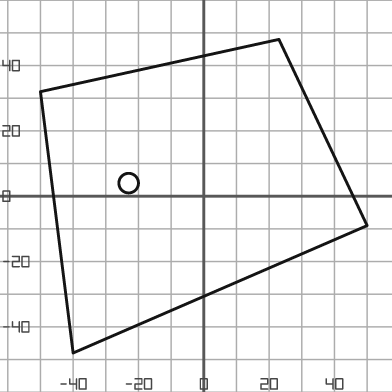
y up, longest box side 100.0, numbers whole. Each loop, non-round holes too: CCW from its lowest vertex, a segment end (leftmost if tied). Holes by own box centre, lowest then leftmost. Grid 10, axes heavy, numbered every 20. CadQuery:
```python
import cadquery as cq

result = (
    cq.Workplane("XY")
    .moveTo(-40.0, -48.0)
    .lineTo(50.0, -9.0)
    .lineTo(23.0, 48.0)
    .lineTo(-50.0, 32.0)
    .close()
    .moveTo(-23.0, 4.0)
    .circle(3.0)
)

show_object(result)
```